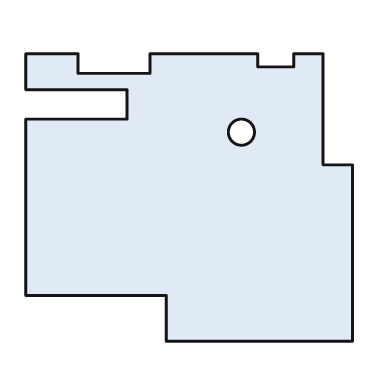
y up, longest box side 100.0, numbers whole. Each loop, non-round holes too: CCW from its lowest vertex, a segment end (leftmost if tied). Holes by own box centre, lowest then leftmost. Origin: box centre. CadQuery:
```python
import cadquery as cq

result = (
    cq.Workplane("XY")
    .moveTo(-7.0, -44.0)
    .lineTo(50.0, -44.0)
    .lineTo(50.0, 10.0)
    .lineTo(41.0, 10.0)
    .lineTo(41.0, 44.0)
    .lineTo(32.0, 44.0)
    .lineTo(32.0, 40.0)
    .lineTo(21.0, 40.0)
    .lineTo(21.0, 44.0)
    .lineTo(-12.0, 44.0)
    .lineTo(-12.0, 38.0)
    .lineTo(-34.0, 38.0)
    .lineTo(-34.0, 44.0)
    .lineTo(-50.0, 44.0)
    .lineTo(-50.0, 33.0)
    .lineTo(-19.0, 33.0)
    .lineTo(-19.0, 24.0)
    .lineTo(-50.0, 24.0)
    .lineTo(-50.0, -30.0)
    .lineTo(-7.0, -30.0)
    .close()
    .moveTo(16.0, 20.0)
    .circle(4.0)
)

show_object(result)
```